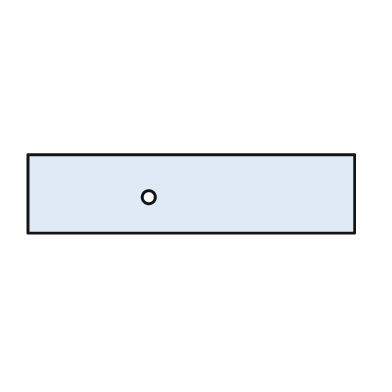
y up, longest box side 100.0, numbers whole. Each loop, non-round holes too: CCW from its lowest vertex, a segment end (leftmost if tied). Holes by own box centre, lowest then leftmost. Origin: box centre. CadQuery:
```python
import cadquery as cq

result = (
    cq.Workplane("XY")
    .moveTo(-50.0, -12.0)
    .lineTo(50.0, -12.0)
    .lineTo(50.0, 12.0)
    .lineTo(-50.0, 12.0)
    .close()
    .moveTo(-13.0, -1.0)
    .circle(2.0)
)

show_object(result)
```